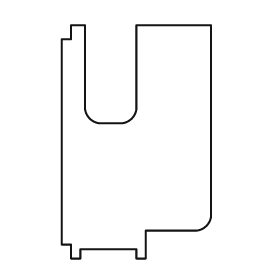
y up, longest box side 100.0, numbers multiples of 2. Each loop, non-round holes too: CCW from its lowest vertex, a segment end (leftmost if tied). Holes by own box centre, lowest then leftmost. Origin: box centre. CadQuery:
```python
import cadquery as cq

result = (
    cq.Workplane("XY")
    .moveTo(-28.0, -50.0)
    .lineTo(-24.0, -50.0)
    .lineTo(-24.0, -46.0)
    .lineTo(0.0, -46.0)
    .lineTo(0.0, -50.0)
    .lineTo(4.0, -50.0)
    .lineTo(4.0, -38.0)
    .lineTo(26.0, -38.0)
    .threePointArc((30.0, -36.0), (32.0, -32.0))
    .lineTo(32.0, 50.0)
    .lineTo(0.0, 50.0)
    .lineTo(0.0, 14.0)
    .threePointArc((-2.0, 10.0), (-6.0, 8.0))
    .lineTo(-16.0, 8.0)
    .threePointArc((-20.0, 10.0), (-22.0, 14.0))
    .lineTo(-22.0, 50.0)
    .lineTo(-28.0, 50.0)
    .lineTo(-28.0, 44.0)
    .lineTo(-32.0, 44.0)
    .lineTo(-32.0, -44.0)
    .lineTo(-28.0, -44.0)
    .close()
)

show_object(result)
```